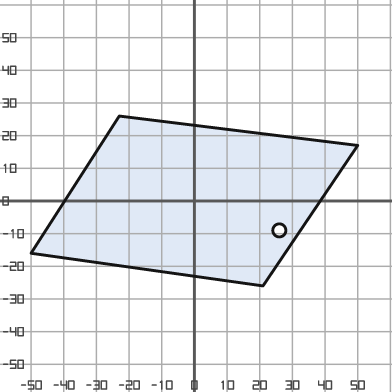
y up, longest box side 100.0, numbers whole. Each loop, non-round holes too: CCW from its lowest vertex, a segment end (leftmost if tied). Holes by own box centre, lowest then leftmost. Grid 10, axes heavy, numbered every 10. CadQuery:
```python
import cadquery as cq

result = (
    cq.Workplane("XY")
    .moveTo(21.0, -26.0)
    .lineTo(50.0, 17.0)
    .lineTo(-23.0, 26.0)
    .lineTo(-50.0, -16.0)
    .close()
    .moveTo(26.0, -9.0)
    .circle(2.0)
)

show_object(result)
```